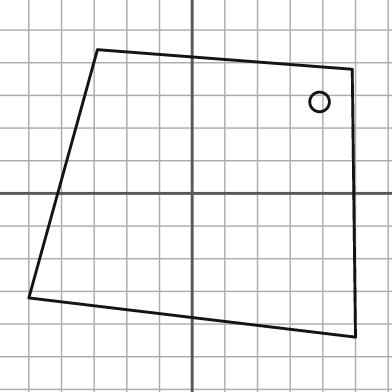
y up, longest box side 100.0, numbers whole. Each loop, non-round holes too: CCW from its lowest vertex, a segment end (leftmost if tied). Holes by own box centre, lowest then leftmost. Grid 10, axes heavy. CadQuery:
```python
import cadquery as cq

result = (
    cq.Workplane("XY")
    .moveTo(50.0, -44.0)
    .lineTo(49.0, 38.0)
    .lineTo(-29.0, 44.0)
    .lineTo(-50.0, -32.0)
    .close()
    .moveTo(39.0, 28.0)
    .circle(3.0)
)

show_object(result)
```